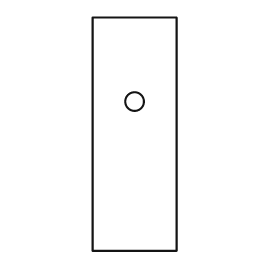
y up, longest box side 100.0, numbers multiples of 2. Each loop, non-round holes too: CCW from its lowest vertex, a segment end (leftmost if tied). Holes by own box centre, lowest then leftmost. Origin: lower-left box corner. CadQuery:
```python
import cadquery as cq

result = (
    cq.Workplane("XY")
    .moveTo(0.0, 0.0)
    .lineTo(36.0, 0.0)
    .lineTo(36.0, 100.0)
    .lineTo(0.0, 100.0)
    .close()
    .moveTo(18.0, 64.0)
    .circle(4.0)
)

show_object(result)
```